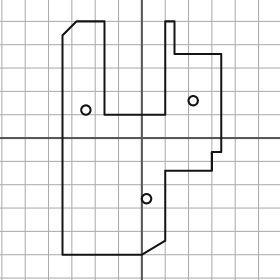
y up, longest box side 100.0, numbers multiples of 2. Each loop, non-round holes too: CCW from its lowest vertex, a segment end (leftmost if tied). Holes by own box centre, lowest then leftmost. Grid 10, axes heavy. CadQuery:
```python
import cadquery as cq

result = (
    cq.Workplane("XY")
    .moveTo(-34.0, -50.0)
    .lineTo(0.0, -50.0)
    .lineTo(10.0, -44.0)
    .lineTo(10.0, -14.0)
    .lineTo(30.0, -14.0)
    .lineTo(30.0, -6.0)
    .lineTo(34.0, -6.0)
    .lineTo(34.0, 36.0)
    .lineTo(14.0, 36.0)
    .lineTo(14.0, 50.0)
    .lineTo(10.0, 50.0)
    .lineTo(10.0, 10.0)
    .lineTo(-16.0, 10.0)
    .lineTo(-16.0, 50.0)
    .lineTo(-28.0, 50.0)
    .lineTo(-34.0, 44.0)
    .close()
    .moveTo(2.0, -26.0)
    .circle(2.0)
    .moveTo(-24.0, 12.0)
    .circle(2.0)
    .moveTo(22.0, 16.0)
    .circle(2.0)
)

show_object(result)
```